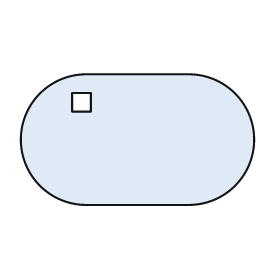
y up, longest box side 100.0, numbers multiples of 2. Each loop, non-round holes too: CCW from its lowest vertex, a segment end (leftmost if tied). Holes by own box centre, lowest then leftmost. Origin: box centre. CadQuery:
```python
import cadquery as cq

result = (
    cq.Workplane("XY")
    .moveTo(-22.0, -28.0)
    .lineTo(22.0, -28.0)
    .threePointArc((50.0, 0.0), (22.0, 28.0))
    .lineTo(-22.0, 28.0)
    .threePointArc((-50.0, 0.0), (-22.0, -28.0))
    .close()
    .moveTo(-28.0, 12.0)
    .lineTo(-20.0, 12.0)
    .lineTo(-20.0, 20.0)
    .lineTo(-28.0, 20.0)
    .close()
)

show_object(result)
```